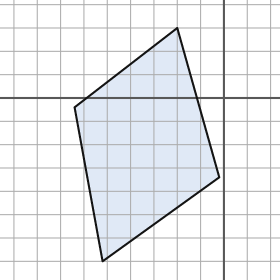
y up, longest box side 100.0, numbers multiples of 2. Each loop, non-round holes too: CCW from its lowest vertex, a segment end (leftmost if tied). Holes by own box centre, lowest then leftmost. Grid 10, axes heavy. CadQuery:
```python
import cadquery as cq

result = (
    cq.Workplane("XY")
    .moveTo(-52.0, -70.0)
    .lineTo(-2.0, -34.0)
    .lineTo(-20.0, 30.0)
    .lineTo(-64.0, -4.0)
    .close()
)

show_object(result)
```